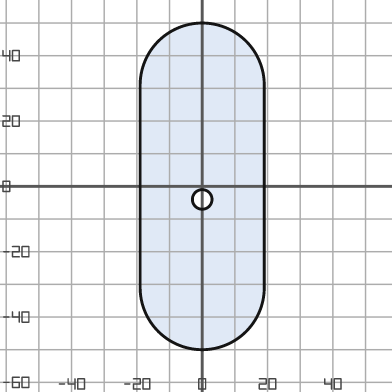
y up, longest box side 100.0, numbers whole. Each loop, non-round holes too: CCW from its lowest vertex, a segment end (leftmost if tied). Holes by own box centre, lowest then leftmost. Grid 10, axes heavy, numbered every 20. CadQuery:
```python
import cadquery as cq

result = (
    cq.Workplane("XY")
    .moveTo(-19.0, -31.0)
    .threePointArc((0.0, -50.0), (19.0, -31.0))
    .lineTo(19.0, 31.0)
    .threePointArc((0.0, 50.0), (-19.0, 31.0))
    .close()
    .moveTo(0.0, -4.0)
    .circle(3.0)
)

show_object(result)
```